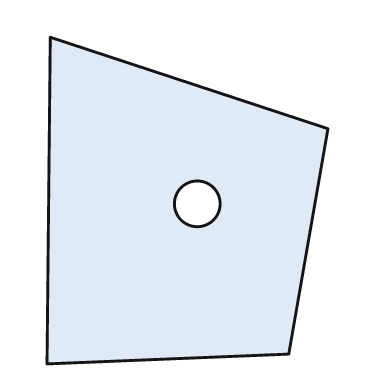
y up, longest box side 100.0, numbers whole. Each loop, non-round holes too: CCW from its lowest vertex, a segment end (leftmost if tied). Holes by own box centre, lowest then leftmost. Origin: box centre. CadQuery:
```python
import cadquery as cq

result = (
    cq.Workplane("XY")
    .moveTo(-43.0, -50.0)
    .lineTo(31.0, -47.0)
    .lineTo(43.0, 22.0)
    .lineTo(-42.0, 50.0)
    .close()
    .moveTo(3.0, -1.0)
    .circle(7.0)
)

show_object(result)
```